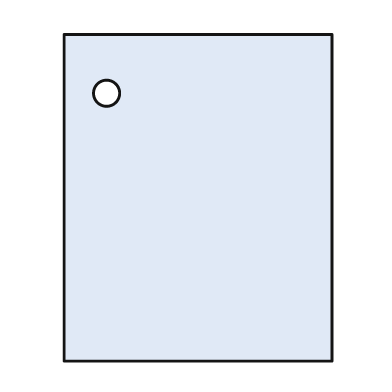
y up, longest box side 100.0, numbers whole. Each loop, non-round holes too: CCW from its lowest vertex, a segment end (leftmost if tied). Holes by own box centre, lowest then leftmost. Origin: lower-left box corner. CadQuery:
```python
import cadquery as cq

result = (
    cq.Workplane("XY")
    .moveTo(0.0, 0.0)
    .lineTo(82.0, 0.0)
    .lineTo(82.0, 100.0)
    .lineTo(0.0, 100.0)
    .close()
    .moveTo(13.0, 82.0)
    .circle(4.0)
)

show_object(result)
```